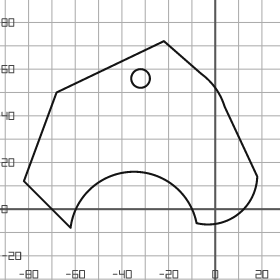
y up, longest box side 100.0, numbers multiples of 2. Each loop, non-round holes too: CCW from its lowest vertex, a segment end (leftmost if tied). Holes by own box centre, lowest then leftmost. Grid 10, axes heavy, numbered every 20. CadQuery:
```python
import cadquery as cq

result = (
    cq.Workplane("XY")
    .moveTo(-62.0, -8.0)
    .threePointArc((-36.0, 16.0), (-8.0, -6.0))
    .threePointArc((10.0, -2.0), (18.0, 14.0))
    .lineTo(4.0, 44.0)
    .threePointArc((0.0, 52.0), (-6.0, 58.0))
    .lineTo(-22.0, 72.0)
    .lineTo(-68.0, 50.0)
    .lineTo(-82.0, 12.0)
    .close()
    .moveTo(-32.0, 56.0)
    .circle(4.0)
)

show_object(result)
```